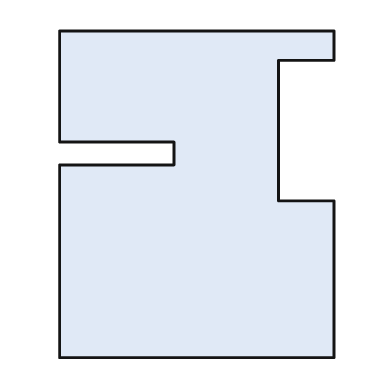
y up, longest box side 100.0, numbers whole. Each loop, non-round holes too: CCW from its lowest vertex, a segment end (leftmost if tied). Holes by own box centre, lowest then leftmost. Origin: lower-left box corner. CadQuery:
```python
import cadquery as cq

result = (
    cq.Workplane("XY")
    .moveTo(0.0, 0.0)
    .lineTo(84.0, 0.0)
    .lineTo(84.0, 48.0)
    .lineTo(67.0, 48.0)
    .lineTo(67.0, 91.0)
    .lineTo(84.0, 91.0)
    .lineTo(84.0, 100.0)
    .lineTo(0.0, 100.0)
    .lineTo(0.0, 66.0)
    .lineTo(35.0, 66.0)
    .lineTo(35.0, 59.0)
    .lineTo(0.0, 59.0)
    .close()
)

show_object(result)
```